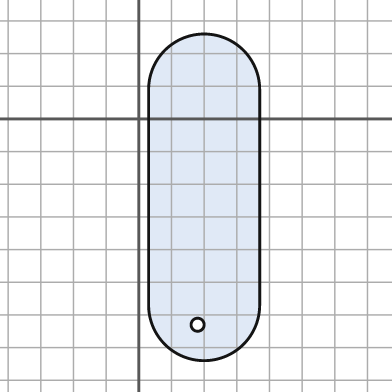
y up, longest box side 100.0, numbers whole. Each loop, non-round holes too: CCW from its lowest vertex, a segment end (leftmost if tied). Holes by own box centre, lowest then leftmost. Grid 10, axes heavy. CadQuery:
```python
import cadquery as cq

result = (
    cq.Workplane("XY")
    .moveTo(3.0, -57.0)
    .threePointArc((20.0, -74.0), (37.0, -57.0))
    .lineTo(37.0, 9.0)
    .threePointArc((20.0, 26.0), (3.0, 9.0))
    .close()
    .moveTo(18.0, -63.0)
    .circle(2.0)
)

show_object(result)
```